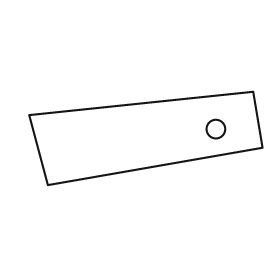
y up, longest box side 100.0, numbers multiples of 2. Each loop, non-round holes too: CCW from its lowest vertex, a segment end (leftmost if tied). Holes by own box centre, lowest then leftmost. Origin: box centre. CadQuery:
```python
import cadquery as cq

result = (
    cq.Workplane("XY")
    .moveTo(-42.0, -20.0)
    .lineTo(50.0, -4.0)
    .lineTo(46.0, 20.0)
    .lineTo(-50.0, 10.0)
    .close()
    .moveTo(30.0, 4.0)
    .circle(4.0)
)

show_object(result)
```